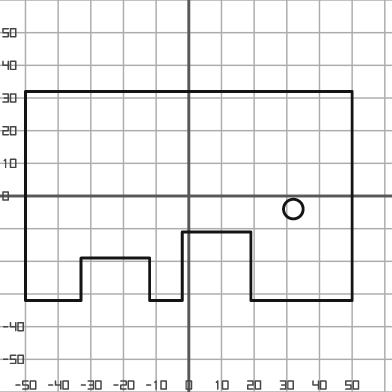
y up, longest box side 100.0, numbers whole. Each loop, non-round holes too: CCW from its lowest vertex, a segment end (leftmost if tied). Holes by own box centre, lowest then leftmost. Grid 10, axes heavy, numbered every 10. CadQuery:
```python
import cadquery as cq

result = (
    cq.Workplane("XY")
    .moveTo(-50.0, -32.0)
    .lineTo(-33.0, -32.0)
    .lineTo(-33.0, -19.0)
    .lineTo(-12.0, -19.0)
    .lineTo(-12.0, -32.0)
    .lineTo(-2.0, -32.0)
    .lineTo(-2.0, -11.0)
    .lineTo(19.0, -11.0)
    .lineTo(19.0, -32.0)
    .lineTo(50.0, -32.0)
    .lineTo(50.0, 32.0)
    .lineTo(-50.0, 32.0)
    .close()
    .moveTo(32.0, -4.0)
    .circle(3.0)
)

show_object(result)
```